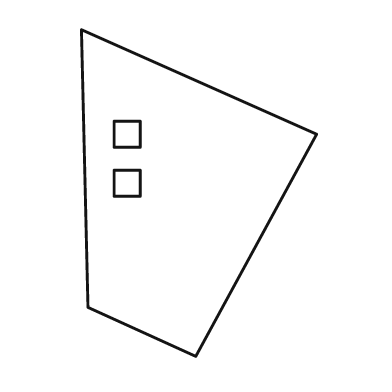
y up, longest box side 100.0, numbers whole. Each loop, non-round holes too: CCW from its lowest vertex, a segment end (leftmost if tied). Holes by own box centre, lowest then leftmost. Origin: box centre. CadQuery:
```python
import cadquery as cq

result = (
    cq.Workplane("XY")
    .moveTo(-1.0, -50.0)
    .lineTo(36.0, 18.0)
    .lineTo(-36.0, 50.0)
    .lineTo(-34.0, -35.0)
    .close()
    .moveTo(-26.0, -1.0)
    .lineTo(-18.0, -1.0)
    .lineTo(-18.0, 7.0)
    .lineTo(-26.0, 7.0)
    .close()
    .moveTo(-26.0, 14.0)
    .lineTo(-18.0, 14.0)
    .lineTo(-18.0, 22.0)
    .lineTo(-26.0, 22.0)
    .close()
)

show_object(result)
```